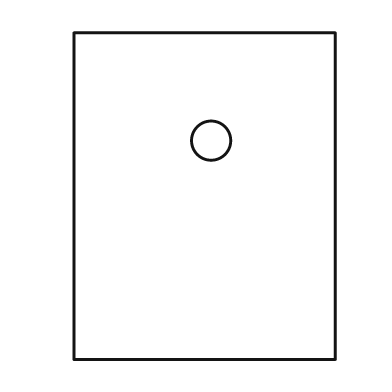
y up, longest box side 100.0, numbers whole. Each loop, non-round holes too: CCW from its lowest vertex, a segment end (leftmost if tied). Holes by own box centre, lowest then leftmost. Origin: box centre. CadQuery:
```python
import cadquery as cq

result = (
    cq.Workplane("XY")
    .moveTo(-40.0, -50.0)
    .lineTo(40.0, -50.0)
    .lineTo(40.0, 50.0)
    .lineTo(-40.0, 50.0)
    .close()
    .moveTo(2.0, 17.0)
    .circle(6.0)
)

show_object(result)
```